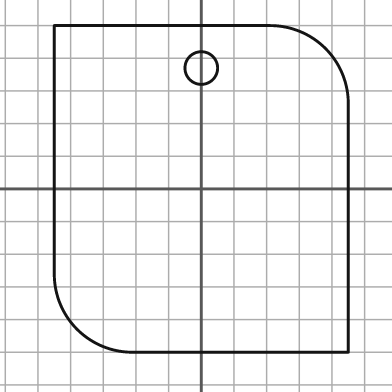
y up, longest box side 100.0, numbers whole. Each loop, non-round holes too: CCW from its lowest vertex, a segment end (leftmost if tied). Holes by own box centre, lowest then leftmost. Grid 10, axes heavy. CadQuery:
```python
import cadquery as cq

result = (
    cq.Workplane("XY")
    .moveTo(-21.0, -50.0)
    .lineTo(45.0, -50.0)
    .lineTo(45.0, 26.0)
    .threePointArc((38.0, 43.0), (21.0, 50.0))
    .lineTo(-45.0, 50.0)
    .lineTo(-45.0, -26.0)
    .threePointArc((-38.0, -43.0), (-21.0, -50.0))
    .close()
    .moveTo(0.0, 37.0)
    .circle(5.0)
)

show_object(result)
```